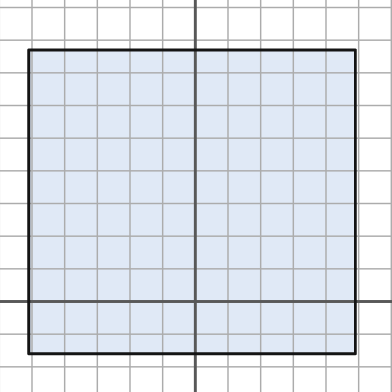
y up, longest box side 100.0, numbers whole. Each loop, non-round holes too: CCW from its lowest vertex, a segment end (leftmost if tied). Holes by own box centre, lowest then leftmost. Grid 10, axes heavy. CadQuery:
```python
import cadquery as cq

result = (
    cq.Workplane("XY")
    .moveTo(-51.0, -16.0)
    .lineTo(49.0, -16.0)
    .lineTo(49.0, 77.0)
    .lineTo(-51.0, 77.0)
    .close()
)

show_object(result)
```